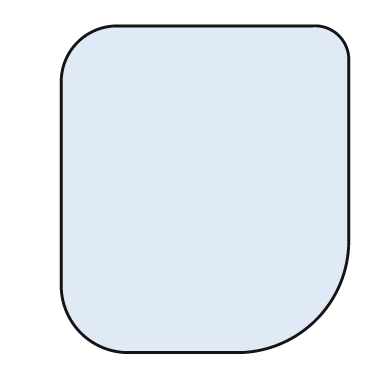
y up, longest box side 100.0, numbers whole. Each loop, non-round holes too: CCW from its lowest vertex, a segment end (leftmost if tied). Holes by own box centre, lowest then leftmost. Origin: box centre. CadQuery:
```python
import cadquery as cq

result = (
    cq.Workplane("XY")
    .moveTo(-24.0, -50.0)
    .lineTo(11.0, -50.0)
    .threePointArc((34.0, -40.0), (44.0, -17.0))
    .lineTo(44.0, 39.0)
    .threePointArc((41.0, 47.0), (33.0, 50.0))
    .lineTo(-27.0, 50.0)
    .threePointArc((-39.0, 45.0), (-44.0, 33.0))
    .lineTo(-44.0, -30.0)
    .threePointArc((-38.0, -44.0), (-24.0, -50.0))
    .close()
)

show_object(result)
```